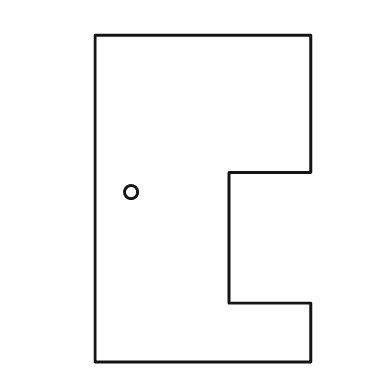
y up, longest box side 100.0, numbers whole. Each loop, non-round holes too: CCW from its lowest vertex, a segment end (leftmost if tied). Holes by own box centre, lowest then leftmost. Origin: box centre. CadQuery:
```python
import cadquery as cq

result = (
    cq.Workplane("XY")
    .moveTo(-33.0, -50.0)
    .lineTo(33.0, -50.0)
    .lineTo(33.0, -32.0)
    .lineTo(8.0, -32.0)
    .lineTo(8.0, 8.0)
    .lineTo(33.0, 8.0)
    .lineTo(33.0, 50.0)
    .lineTo(-33.0, 50.0)
    .close()
    .moveTo(-22.0, 2.0)
    .circle(2.0)
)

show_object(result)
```